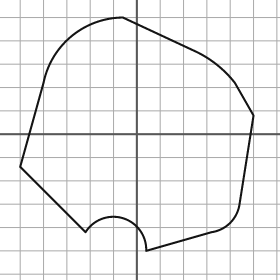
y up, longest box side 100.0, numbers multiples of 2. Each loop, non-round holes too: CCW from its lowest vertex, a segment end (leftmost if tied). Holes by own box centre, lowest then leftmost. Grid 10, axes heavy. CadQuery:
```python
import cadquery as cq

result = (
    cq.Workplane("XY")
    .moveTo(4.0, -50.0)
    .lineTo(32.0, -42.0)
    .threePointArc((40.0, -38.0), (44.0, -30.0))
    .lineTo(50.0, 8.0)
    .lineTo(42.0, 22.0)
    .threePointArc((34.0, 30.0), (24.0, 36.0))
    .lineTo(-6.0, 50.0)
    .threePointArc((-28.0, 42.0), (-40.0, 22.0))
    .lineTo(-50.0, -14.0)
    .lineTo(-22.0, -42.0)
    .threePointArc((-6.0, -36.0), (4.0, -50.0))
    .close()
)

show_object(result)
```